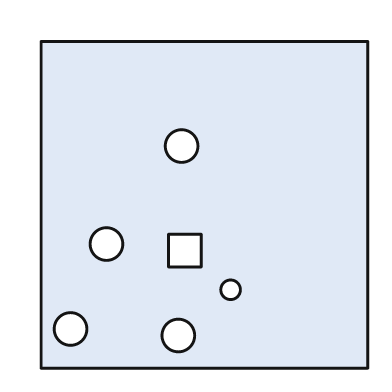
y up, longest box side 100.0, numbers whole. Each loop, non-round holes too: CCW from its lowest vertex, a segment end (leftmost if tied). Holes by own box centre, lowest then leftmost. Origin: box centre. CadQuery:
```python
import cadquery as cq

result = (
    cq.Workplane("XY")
    .moveTo(-50.0, -50.0)
    .lineTo(50.0, -50.0)
    .lineTo(50.0, 50.0)
    .lineTo(-50.0, 50.0)
    .close()
    .moveTo(-8.0, -40.0)
    .circle(5.0)
    .moveTo(-41.0, -38.0)
    .circle(5.0)
    .moveTo(8.0, -26.0)
    .circle(3.0)
    .moveTo(-11.0, -19.0)
    .lineTo(-1.0, -19.0)
    .lineTo(-1.0, -9.0)
    .lineTo(-11.0, -9.0)
    .close()
    .moveTo(-30.0, -12.0)
    .circle(5.0)
    .moveTo(-7.0, 18.0)
    .circle(5.0)
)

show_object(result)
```